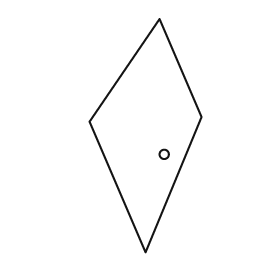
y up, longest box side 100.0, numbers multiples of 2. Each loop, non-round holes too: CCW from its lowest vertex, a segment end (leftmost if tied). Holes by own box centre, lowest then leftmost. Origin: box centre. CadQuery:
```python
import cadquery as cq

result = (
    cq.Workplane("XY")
    .moveTo(0.0, -50.0)
    .lineTo(24.0, 8.0)
    .lineTo(6.0, 50.0)
    .lineTo(-24.0, 6.0)
    .close()
    .moveTo(8.0, -8.0)
    .circle(2.0)
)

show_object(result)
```